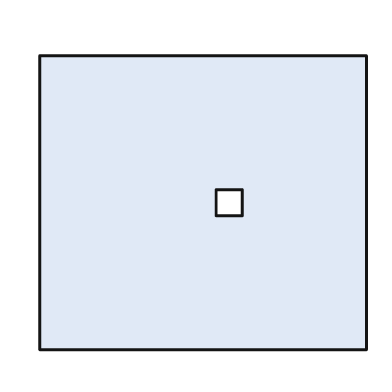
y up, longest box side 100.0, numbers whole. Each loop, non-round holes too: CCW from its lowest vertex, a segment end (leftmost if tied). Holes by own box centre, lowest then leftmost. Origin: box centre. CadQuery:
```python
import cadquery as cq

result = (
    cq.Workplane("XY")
    .moveTo(-50.0, -45.0)
    .lineTo(50.0, -45.0)
    .lineTo(50.0, 45.0)
    .lineTo(-50.0, 45.0)
    .close()
    .moveTo(4.0, -4.0)
    .lineTo(12.0, -4.0)
    .lineTo(12.0, 4.0)
    .lineTo(4.0, 4.0)
    .close()
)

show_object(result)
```